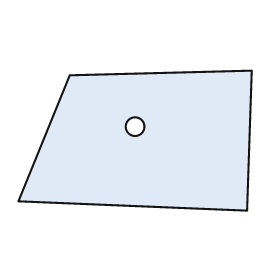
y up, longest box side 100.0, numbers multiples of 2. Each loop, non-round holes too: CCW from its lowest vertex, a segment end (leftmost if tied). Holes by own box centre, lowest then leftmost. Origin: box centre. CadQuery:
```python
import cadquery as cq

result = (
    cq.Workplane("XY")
    .moveTo(48.0, -30.0)
    .lineTo(50.0, 30.0)
    .lineTo(-28.0, 28.0)
    .lineTo(-50.0, -26.0)
    .close()
    .moveTo(0.0, 6.0)
    .circle(4.0)
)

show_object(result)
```